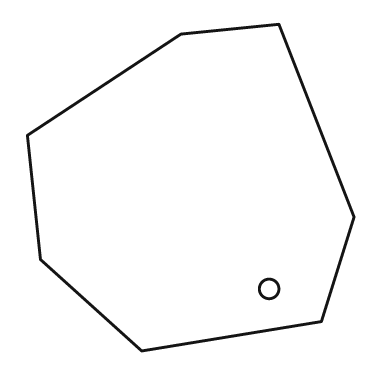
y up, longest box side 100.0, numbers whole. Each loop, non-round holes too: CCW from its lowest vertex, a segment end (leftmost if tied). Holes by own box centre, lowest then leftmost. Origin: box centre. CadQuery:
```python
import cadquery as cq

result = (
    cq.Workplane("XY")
    .moveTo(-15.0, -50.0)
    .lineTo(40.0, -41.0)
    .lineTo(50.0, -9.0)
    .lineTo(27.0, 50.0)
    .lineTo(-3.0, 47.0)
    .lineTo(-50.0, 16.0)
    .lineTo(-46.0, -22.0)
    .close()
    .moveTo(24.0, -31.0)
    .circle(3.0)
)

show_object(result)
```